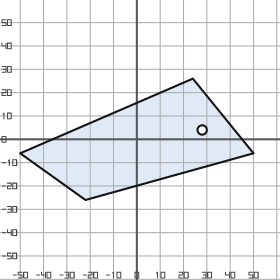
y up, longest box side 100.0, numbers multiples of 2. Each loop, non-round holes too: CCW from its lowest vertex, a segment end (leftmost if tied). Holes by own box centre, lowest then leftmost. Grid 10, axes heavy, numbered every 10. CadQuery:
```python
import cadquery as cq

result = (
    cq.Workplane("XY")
    .moveTo(-22.0, -26.0)
    .lineTo(50.0, -6.0)
    .lineTo(24.0, 26.0)
    .lineTo(-50.0, -6.0)
    .close()
    .moveTo(28.0, 4.0)
    .circle(2.0)
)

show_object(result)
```